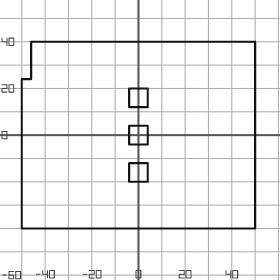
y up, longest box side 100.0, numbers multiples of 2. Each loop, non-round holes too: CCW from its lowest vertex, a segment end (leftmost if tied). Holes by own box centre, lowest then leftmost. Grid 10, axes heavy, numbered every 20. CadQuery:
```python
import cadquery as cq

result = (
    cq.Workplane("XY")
    .moveTo(-50.0, -40.0)
    .lineTo(50.0, -40.0)
    .lineTo(50.0, 40.0)
    .lineTo(-46.0, 40.0)
    .lineTo(-46.0, 24.0)
    .lineTo(-50.0, 24.0)
    .close()
    .moveTo(-4.0, -20.0)
    .lineTo(4.0, -20.0)
    .lineTo(4.0, -12.0)
    .lineTo(-4.0, -12.0)
    .close()
    .moveTo(-4.0, -4.0)
    .lineTo(4.0, -4.0)
    .lineTo(4.0, 4.0)
    .lineTo(-4.0, 4.0)
    .close()
    .moveTo(-4.0, 12.0)
    .lineTo(4.0, 12.0)
    .lineTo(4.0, 20.0)
    .lineTo(-4.0, 20.0)
    .close()
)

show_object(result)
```